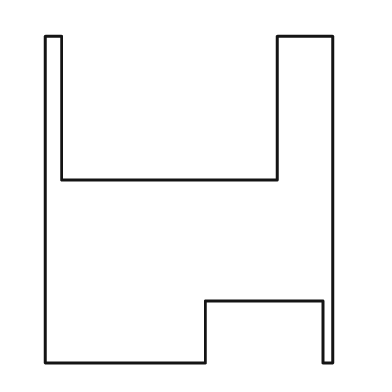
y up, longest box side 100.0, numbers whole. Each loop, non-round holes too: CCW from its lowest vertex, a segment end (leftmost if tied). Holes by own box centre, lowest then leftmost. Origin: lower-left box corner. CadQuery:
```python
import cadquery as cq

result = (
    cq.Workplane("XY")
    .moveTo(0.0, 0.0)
    .lineTo(49.0, 0.0)
    .lineTo(49.0, 19.0)
    .lineTo(85.0, 19.0)
    .lineTo(85.0, 0.0)
    .lineTo(88.0, 0.0)
    .lineTo(88.0, 100.0)
    .lineTo(71.0, 100.0)
    .lineTo(71.0, 56.0)
    .lineTo(5.0, 56.0)
    .lineTo(5.0, 100.0)
    .lineTo(0.0, 100.0)
    .close()
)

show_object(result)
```